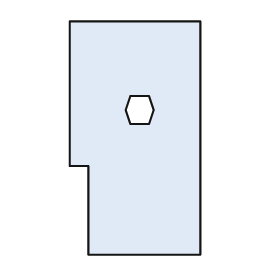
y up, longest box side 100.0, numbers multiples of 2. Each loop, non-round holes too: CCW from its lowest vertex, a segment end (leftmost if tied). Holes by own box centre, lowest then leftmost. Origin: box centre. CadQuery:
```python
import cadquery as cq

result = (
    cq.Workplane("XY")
    .moveTo(-20.0, -50.0)
    .lineTo(28.0, -50.0)
    .lineTo(28.0, 50.0)
    .lineTo(-28.0, 50.0)
    .lineTo(-28.0, -12.0)
    .lineTo(-20.0, -12.0)
    .close()
    .moveTo(-2.0, 6.0)
    .lineTo(6.0, 6.0)
    .lineTo(8.0, 12.0)
    .lineTo(6.0, 18.0)
    .lineTo(-2.0, 18.0)
    .lineTo(-4.0, 12.0)
    .close()
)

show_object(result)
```